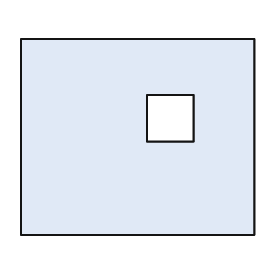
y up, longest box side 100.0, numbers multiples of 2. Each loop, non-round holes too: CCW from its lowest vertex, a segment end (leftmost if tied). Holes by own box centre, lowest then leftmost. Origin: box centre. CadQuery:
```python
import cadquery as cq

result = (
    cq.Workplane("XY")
    .moveTo(-50.0, -42.0)
    .lineTo(50.0, -42.0)
    .lineTo(50.0, 42.0)
    .lineTo(-50.0, 42.0)
    .close()
    .moveTo(4.0, -2.0)
    .lineTo(24.0, -2.0)
    .lineTo(24.0, 18.0)
    .lineTo(4.0, 18.0)
    .close()
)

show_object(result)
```